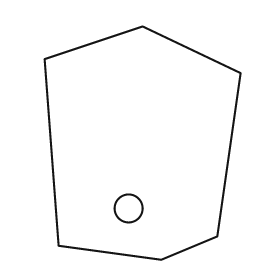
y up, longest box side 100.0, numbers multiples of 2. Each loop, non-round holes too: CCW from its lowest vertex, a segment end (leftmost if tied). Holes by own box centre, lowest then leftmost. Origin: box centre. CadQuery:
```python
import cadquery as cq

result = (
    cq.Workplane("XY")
    .moveTo(8.0, -50.0)
    .lineTo(32.0, -40.0)
    .lineTo(42.0, 30.0)
    .lineTo(0.0, 50.0)
    .lineTo(-42.0, 36.0)
    .lineTo(-36.0, -44.0)
    .close()
    .moveTo(-6.0, -28.0)
    .circle(6.0)
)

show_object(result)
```